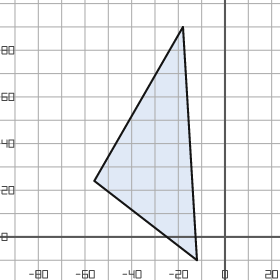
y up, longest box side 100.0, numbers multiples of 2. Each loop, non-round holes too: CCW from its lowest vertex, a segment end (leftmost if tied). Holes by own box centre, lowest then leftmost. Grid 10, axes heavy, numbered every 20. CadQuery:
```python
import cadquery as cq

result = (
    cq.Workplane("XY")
    .moveTo(-12.0, -10.0)
    .lineTo(-18.0, 90.0)
    .lineTo(-56.0, 24.0)
    .close()
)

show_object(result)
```